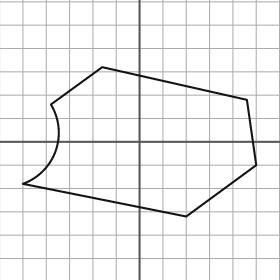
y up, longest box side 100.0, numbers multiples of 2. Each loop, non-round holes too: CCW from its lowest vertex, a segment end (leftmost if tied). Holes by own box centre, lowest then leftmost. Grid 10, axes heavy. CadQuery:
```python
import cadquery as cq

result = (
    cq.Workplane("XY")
    .moveTo(20.0, -32.0)
    .lineTo(50.0, -10.0)
    .lineTo(46.0, 18.0)
    .lineTo(-16.0, 32.0)
    .lineTo(-38.0, 16.0)
    .threePointArc((-36.0, -4.0), (-50.0, -18.0))
    .close()
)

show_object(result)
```